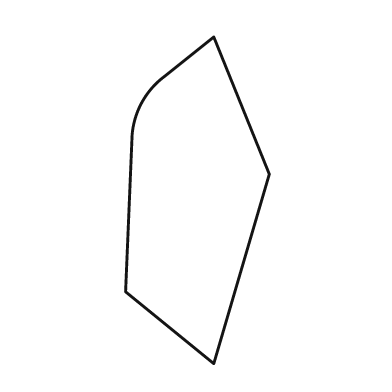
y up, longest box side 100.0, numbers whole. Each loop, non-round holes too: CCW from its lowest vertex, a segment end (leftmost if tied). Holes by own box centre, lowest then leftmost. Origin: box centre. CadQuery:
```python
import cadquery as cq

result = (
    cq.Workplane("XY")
    .moveTo(5.0, -50.0)
    .lineTo(22.0, 8.0)
    .lineTo(5.0, 50.0)
    .lineTo(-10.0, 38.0)
    .threePointArc((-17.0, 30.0), (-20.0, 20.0))
    .lineTo(-22.0, -28.0)
    .close()
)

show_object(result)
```